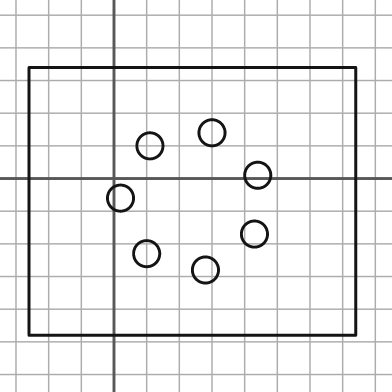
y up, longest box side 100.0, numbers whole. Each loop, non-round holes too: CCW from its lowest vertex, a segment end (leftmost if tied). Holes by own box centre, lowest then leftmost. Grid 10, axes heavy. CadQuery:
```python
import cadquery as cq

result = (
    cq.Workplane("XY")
    .moveTo(-26.0, -48.0)
    .lineTo(74.0, -48.0)
    .lineTo(74.0, 34.0)
    .lineTo(-26.0, 34.0)
    .close()
    .moveTo(28.0, -28.0)
    .circle(4.0)
    .moveTo(10.0, -23.0)
    .circle(4.0)
    .moveTo(43.0, -17.0)
    .circle(4.0)
    .moveTo(2.0, -6.0)
    .circle(4.0)
    .moveTo(44.0, 1.0)
    .circle(4.0)
    .moveTo(11.0, 10.0)
    .circle(4.0)
    .moveTo(30.0, 14.0)
    .circle(4.0)
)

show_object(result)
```